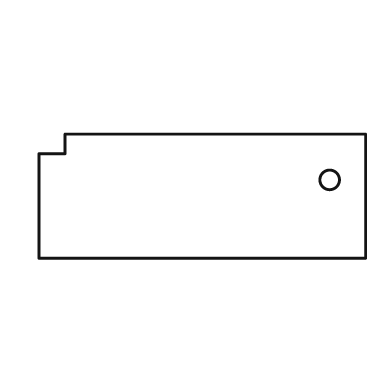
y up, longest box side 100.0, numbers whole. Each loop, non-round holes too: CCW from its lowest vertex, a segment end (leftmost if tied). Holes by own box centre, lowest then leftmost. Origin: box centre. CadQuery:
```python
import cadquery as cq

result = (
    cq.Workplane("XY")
    .moveTo(-50.0, -19.0)
    .lineTo(50.0, -19.0)
    .lineTo(50.0, 19.0)
    .lineTo(-42.0, 19.0)
    .lineTo(-42.0, 13.0)
    .lineTo(-50.0, 13.0)
    .close()
    .moveTo(39.0, 5.0)
    .circle(3.0)
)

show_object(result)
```